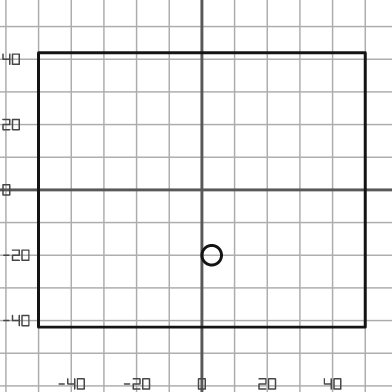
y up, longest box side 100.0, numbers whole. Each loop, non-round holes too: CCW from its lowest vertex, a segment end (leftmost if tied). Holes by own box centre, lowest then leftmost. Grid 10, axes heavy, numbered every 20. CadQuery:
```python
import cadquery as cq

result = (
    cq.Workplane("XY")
    .moveTo(-50.0, -42.0)
    .lineTo(50.0, -42.0)
    .lineTo(50.0, 42.0)
    .lineTo(-50.0, 42.0)
    .close()
    .moveTo(3.0, -20.0)
    .circle(3.0)
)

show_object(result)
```